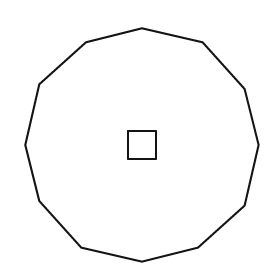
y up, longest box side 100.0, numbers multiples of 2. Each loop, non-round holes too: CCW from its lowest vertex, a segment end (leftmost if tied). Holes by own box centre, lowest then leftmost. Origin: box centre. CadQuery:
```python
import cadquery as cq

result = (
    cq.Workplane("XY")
    .moveTo(0.0, -50.0)
    .lineTo(24.0, -44.0)
    .lineTo(44.0, -26.0)
    .lineTo(50.0, 0.0)
    .lineTo(44.0, 24.0)
    .lineTo(26.0, 44.0)
    .lineTo(0.0, 50.0)
    .lineTo(-24.0, 44.0)
    .lineTo(-44.0, 26.0)
    .lineTo(-50.0, 0.0)
    .lineTo(-44.0, -24.0)
    .lineTo(-26.0, -44.0)
    .close()
    .moveTo(-6.0, -6.0)
    .lineTo(6.0, -6.0)
    .lineTo(6.0, 6.0)
    .lineTo(-6.0, 6.0)
    .close()
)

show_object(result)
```